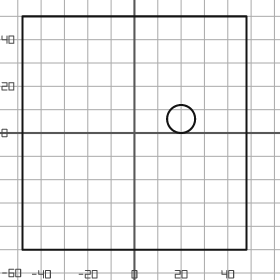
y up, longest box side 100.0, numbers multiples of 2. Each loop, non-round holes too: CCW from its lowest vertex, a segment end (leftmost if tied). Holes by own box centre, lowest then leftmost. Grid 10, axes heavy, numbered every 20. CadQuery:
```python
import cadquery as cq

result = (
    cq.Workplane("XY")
    .moveTo(-48.0, -50.0)
    .lineTo(48.0, -50.0)
    .lineTo(48.0, 50.0)
    .lineTo(-48.0, 50.0)
    .close()
    .moveTo(20.0, 6.0)
    .circle(6.0)
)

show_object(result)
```